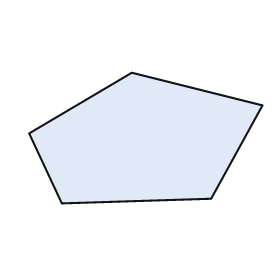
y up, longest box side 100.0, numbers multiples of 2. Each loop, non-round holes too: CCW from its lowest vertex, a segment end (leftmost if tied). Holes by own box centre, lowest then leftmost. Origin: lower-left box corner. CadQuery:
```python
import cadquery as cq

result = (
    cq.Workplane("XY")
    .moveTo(14.0, 0.0)
    .lineTo(78.0, 2.0)
    .lineTo(100.0, 42.0)
    .lineTo(44.0, 56.0)
    .lineTo(0.0, 30.0)
    .close()
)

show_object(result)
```